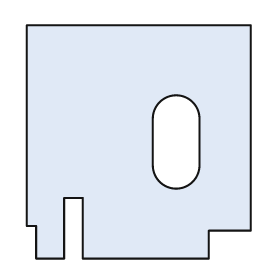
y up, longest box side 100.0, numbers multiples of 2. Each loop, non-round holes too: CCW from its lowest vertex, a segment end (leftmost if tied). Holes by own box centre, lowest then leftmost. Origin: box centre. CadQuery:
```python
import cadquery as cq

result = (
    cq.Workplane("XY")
    .moveTo(-44.0, -50.0)
    .lineTo(-32.0, -50.0)
    .lineTo(-32.0, -24.0)
    .lineTo(-24.0, -24.0)
    .lineTo(-24.0, -50.0)
    .lineTo(30.0, -50.0)
    .lineTo(30.0, -38.0)
    .lineTo(48.0, -38.0)
    .lineTo(48.0, 50.0)
    .lineTo(-48.0, 50.0)
    .lineTo(-48.0, -36.0)
    .lineTo(-44.0, -36.0)
    .close()
    .moveTo(6.0, -10.0)
    .threePointArc((16.0, -20.0), (26.0, -10.0))
    .lineTo(26.0, 10.0)
    .threePointArc((16.0, 20.0), (6.0, 10.0))
    .close()
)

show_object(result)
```